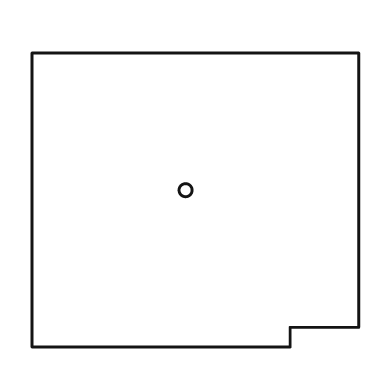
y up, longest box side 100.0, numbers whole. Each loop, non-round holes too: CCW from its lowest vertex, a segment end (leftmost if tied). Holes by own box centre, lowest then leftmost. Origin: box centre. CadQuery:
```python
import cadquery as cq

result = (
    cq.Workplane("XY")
    .moveTo(-50.0, -45.0)
    .lineTo(29.0, -45.0)
    .lineTo(29.0, -39.0)
    .lineTo(50.0, -39.0)
    .lineTo(50.0, 45.0)
    .lineTo(-50.0, 45.0)
    .close()
    .moveTo(-3.0, 3.0)
    .circle(2.0)
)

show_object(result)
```